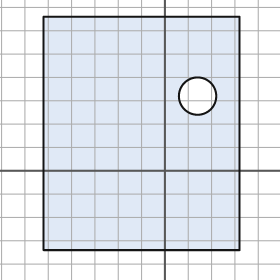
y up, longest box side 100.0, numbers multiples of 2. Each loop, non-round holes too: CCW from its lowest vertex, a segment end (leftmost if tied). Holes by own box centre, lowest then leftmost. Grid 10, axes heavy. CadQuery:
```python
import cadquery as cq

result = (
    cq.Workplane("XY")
    .moveTo(-52.0, -34.0)
    .lineTo(32.0, -34.0)
    .lineTo(32.0, 66.0)
    .lineTo(-52.0, 66.0)
    .close()
    .moveTo(14.0, 32.0)
    .circle(8.0)
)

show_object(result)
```